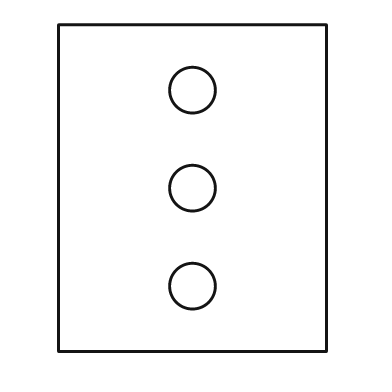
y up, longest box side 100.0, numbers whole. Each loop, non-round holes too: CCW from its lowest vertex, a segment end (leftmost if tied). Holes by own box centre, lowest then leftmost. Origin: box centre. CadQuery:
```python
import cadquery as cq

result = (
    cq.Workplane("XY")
    .moveTo(-41.0, -50.0)
    .lineTo(41.0, -50.0)
    .lineTo(41.0, 50.0)
    .lineTo(-41.0, 50.0)
    .close()
    .moveTo(0.0, -30.0)
    .circle(7.0)
    .moveTo(0.0, 0.0)
    .circle(7.0)
    .moveTo(0.0, 30.0)
    .circle(7.0)
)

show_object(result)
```